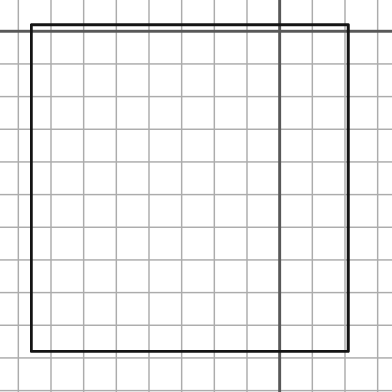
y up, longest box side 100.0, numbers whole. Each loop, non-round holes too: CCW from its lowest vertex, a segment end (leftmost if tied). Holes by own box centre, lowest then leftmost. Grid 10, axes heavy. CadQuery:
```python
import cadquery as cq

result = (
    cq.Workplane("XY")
    .moveTo(-76.0, -98.0)
    .lineTo(21.0, -98.0)
    .lineTo(21.0, 2.0)
    .lineTo(-76.0, 2.0)
    .close()
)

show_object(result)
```